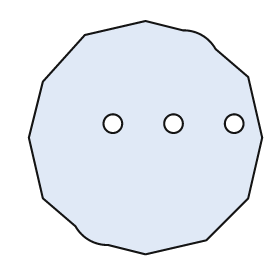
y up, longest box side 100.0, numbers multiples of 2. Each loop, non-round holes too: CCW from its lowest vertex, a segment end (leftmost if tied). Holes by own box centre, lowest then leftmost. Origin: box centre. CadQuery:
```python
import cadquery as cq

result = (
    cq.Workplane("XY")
    .moveTo(0.0, -50.0)
    .lineTo(26.0, -44.0)
    .lineTo(44.0, -26.0)
    .lineTo(50.0, 0.0)
    .lineTo(44.0, 26.0)
    .lineTo(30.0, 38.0)
    .threePointArc((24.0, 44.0), (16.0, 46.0))
    .lineTo(0.0, 50.0)
    .lineTo(-26.0, 44.0)
    .lineTo(-44.0, 24.0)
    .lineTo(-50.0, 0.0)
    .lineTo(-44.0, -26.0)
    .lineTo(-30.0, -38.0)
    .threePointArc((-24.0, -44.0), (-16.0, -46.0))
    .close()
    .moveTo(-14.0, 6.0)
    .circle(4.0)
    .moveTo(12.0, 6.0)
    .circle(4.0)
    .moveTo(38.0, 6.0)
    .circle(4.0)
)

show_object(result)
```